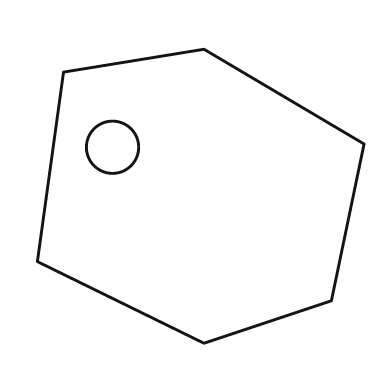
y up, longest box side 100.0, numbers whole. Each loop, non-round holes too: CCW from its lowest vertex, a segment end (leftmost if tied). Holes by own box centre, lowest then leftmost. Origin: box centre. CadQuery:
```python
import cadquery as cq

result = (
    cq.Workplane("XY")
    .moveTo(1.0, -45.0)
    .lineTo(40.0, -32.0)
    .lineTo(50.0, 16.0)
    .lineTo(1.0, 45.0)
    .lineTo(-42.0, 38.0)
    .lineTo(-50.0, -20.0)
    .close()
    .moveTo(-27.0, 15.0)
    .circle(8.0)
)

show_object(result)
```